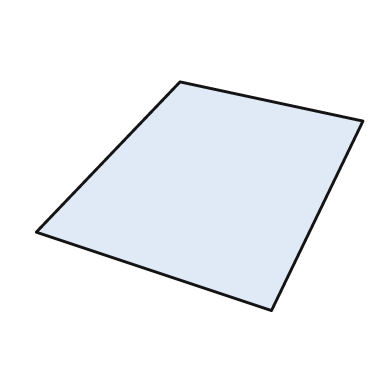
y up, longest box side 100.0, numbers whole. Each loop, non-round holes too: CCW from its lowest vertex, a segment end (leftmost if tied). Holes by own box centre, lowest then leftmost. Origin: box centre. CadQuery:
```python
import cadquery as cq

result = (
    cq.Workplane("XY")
    .moveTo(22.0, -35.0)
    .lineTo(50.0, 23.0)
    .lineTo(-6.0, 35.0)
    .lineTo(-50.0, -11.0)
    .close()
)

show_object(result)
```